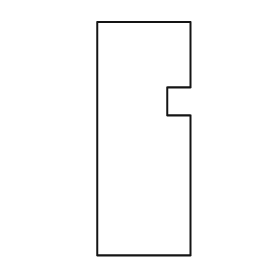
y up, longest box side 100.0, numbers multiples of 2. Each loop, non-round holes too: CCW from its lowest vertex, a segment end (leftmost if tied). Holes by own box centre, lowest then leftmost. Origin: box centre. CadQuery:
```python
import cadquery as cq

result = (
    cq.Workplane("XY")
    .moveTo(-20.0, -50.0)
    .lineTo(20.0, -50.0)
    .lineTo(20.0, 10.0)
    .lineTo(10.0, 10.0)
    .lineTo(10.0, 22.0)
    .lineTo(20.0, 22.0)
    .lineTo(20.0, 50.0)
    .lineTo(-20.0, 50.0)
    .close()
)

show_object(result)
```